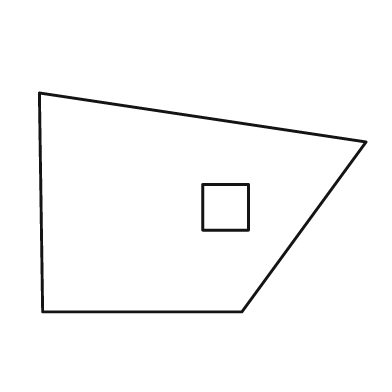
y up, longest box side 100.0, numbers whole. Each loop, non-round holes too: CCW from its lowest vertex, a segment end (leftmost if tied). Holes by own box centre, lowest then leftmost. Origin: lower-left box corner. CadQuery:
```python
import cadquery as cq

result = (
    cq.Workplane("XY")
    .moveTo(1.0, 0.0)
    .lineTo(62.0, 0.0)
    .lineTo(100.0, 52.0)
    .lineTo(0.0, 67.0)
    .close()
    .moveTo(50.0, 25.0)
    .lineTo(64.0, 25.0)
    .lineTo(64.0, 39.0)
    .lineTo(50.0, 39.0)
    .close()
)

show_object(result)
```